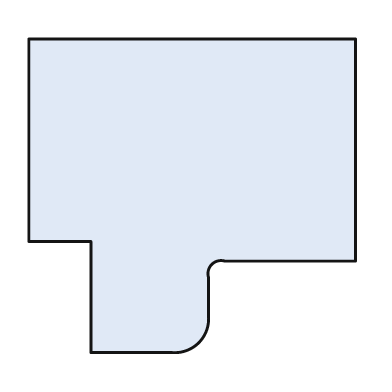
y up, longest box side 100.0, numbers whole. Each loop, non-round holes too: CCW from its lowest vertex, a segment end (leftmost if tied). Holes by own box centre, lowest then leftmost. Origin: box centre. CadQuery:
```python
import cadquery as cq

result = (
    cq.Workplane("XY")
    .moveTo(-31.0, -48.0)
    .lineTo(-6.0, -48.0)
    .threePointArc((2.0, -45.0), (5.0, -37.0))
    .lineTo(5.0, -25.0)
    .threePointArc((6.0, -21.0), (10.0, -20.0))
    .lineTo(50.0, -20.0)
    .lineTo(50.0, 48.0)
    .lineTo(-50.0, 48.0)
    .lineTo(-50.0, -14.0)
    .lineTo(-31.0, -14.0)
    .close()
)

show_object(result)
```